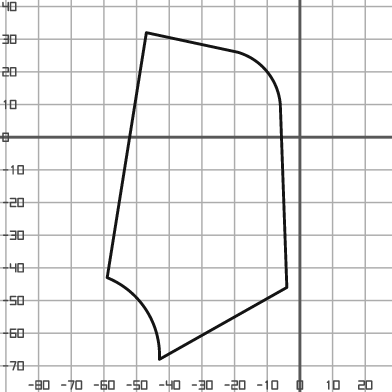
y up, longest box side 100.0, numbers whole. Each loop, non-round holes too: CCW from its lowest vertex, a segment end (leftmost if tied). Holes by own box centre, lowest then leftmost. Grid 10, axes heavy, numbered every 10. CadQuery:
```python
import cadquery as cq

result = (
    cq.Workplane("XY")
    .moveTo(-43.0, -68.0)
    .lineTo(-4.0, -46.0)
    .lineTo(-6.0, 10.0)
    .threePointArc((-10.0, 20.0), (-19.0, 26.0))
    .lineTo(-47.0, 32.0)
    .lineTo(-59.0, -43.0)
    .threePointArc((-47.0, -53.0), (-43.0, -68.0))
    .close()
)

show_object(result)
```